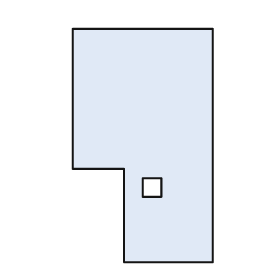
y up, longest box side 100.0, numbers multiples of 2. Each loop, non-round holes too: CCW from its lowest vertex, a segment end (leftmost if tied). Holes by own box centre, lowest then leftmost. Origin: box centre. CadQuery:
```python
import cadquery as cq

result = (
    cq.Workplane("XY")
    .moveTo(-8.0, -50.0)
    .lineTo(30.0, -50.0)
    .lineTo(30.0, 50.0)
    .lineTo(-30.0, 50.0)
    .lineTo(-30.0, -10.0)
    .lineTo(-8.0, -10.0)
    .close()
    .moveTo(0.0, -22.0)
    .lineTo(8.0, -22.0)
    .lineTo(8.0, -14.0)
    .lineTo(0.0, -14.0)
    .close()
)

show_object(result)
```